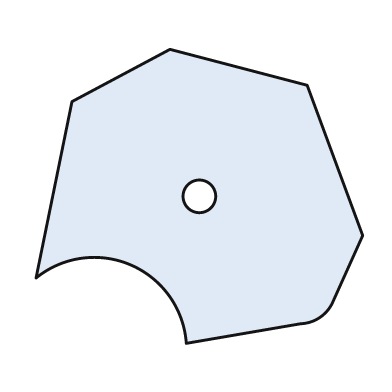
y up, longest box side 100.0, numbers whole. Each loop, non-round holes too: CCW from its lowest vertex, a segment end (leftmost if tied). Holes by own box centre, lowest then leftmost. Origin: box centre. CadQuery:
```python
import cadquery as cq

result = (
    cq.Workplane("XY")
    .moveTo(-4.0, -45.0)
    .lineTo(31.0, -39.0)
    .threePointArc((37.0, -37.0), (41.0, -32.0))
    .lineTo(50.0, -12.0)
    .lineTo(33.0, 34.0)
    .lineTo(-9.0, 45.0)
    .lineTo(-39.0, 29.0)
    .lineTo(-50.0, -25.0)
    .threePointArc((-21.0, -21.0), (-4.0, -45.0))
    .close()
    .moveTo(0.0, 0.0)
    .circle(5.0)
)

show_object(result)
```